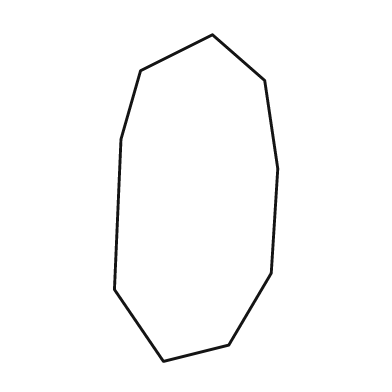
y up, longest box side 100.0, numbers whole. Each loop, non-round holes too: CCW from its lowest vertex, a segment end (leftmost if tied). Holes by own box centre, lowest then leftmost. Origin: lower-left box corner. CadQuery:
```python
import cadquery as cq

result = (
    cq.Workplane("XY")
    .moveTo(15.0, 0.0)
    .lineTo(35.0, 5.0)
    .lineTo(48.0, 27.0)
    .lineTo(50.0, 59.0)
    .lineTo(46.0, 86.0)
    .lineTo(30.0, 100.0)
    .lineTo(8.0, 89.0)
    .lineTo(2.0, 68.0)
    .lineTo(0.0, 22.0)
    .close()
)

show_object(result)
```